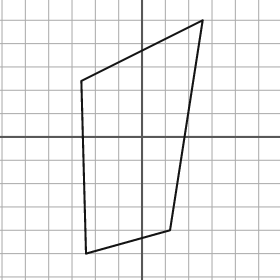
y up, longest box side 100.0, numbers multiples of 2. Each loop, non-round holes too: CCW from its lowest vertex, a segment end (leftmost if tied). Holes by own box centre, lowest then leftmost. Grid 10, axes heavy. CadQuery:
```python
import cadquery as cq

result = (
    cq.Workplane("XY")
    .moveTo(-24.0, -50.0)
    .lineTo(12.0, -40.0)
    .lineTo(26.0, 50.0)
    .lineTo(-26.0, 24.0)
    .close()
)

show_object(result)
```